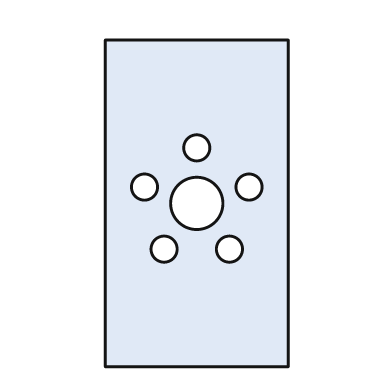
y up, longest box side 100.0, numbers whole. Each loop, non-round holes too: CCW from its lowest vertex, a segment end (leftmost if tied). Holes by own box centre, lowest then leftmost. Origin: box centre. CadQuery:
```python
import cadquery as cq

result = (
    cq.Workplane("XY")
    .moveTo(-28.0, -50.0)
    .lineTo(28.0, -50.0)
    .lineTo(28.0, 50.0)
    .lineTo(-28.0, 50.0)
    .close()
    .moveTo(-10.0, -14.0)
    .circle(4.0)
    .moveTo(10.0, -14.0)
    .circle(4.0)
    .moveTo(0.0, 0.0)
    .circle(8.0)
    .moveTo(-16.0, 5.0)
    .circle(4.0)
    .moveTo(16.0, 5.0)
    .circle(4.0)
    .moveTo(0.0, 17.0)
    .circle(4.0)
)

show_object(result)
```